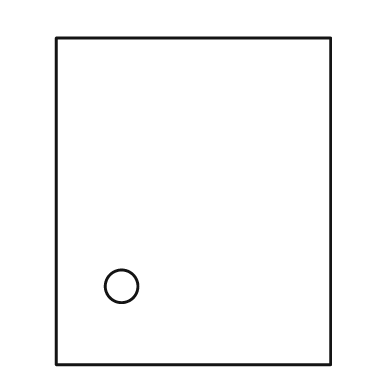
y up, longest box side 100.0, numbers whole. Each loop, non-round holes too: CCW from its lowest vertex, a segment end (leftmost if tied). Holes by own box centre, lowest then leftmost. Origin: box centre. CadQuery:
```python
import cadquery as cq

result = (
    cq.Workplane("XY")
    .moveTo(-42.0, -50.0)
    .lineTo(42.0, -50.0)
    .lineTo(42.0, 50.0)
    .lineTo(-42.0, 50.0)
    .close()
    .moveTo(-22.0, -26.0)
    .circle(5.0)
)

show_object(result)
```